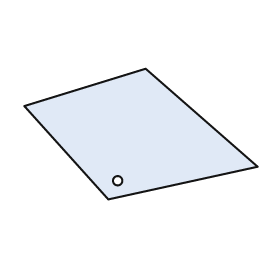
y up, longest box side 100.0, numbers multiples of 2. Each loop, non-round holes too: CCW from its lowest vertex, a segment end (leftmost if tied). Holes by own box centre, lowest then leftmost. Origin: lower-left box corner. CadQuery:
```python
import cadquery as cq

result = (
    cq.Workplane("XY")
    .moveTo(36.0, 0.0)
    .lineTo(100.0, 14.0)
    .lineTo(52.0, 56.0)
    .lineTo(0.0, 40.0)
    .close()
    .moveTo(40.0, 8.0)
    .circle(2.0)
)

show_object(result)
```